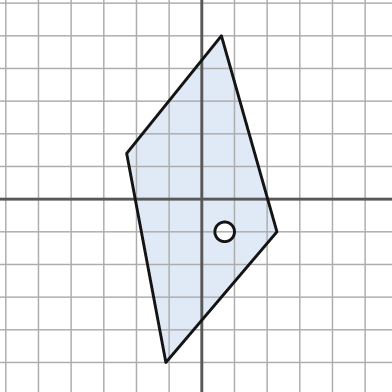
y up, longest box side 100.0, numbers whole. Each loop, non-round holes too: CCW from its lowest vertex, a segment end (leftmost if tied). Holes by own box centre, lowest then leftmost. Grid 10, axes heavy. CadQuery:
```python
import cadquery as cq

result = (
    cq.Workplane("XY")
    .moveTo(-11.0, -50.0)
    .lineTo(23.0, -10.0)
    .lineTo(6.0, 50.0)
    .lineTo(-23.0, 14.0)
    .close()
    .moveTo(7.0, -10.0)
    .circle(3.0)
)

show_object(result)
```